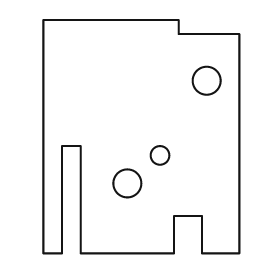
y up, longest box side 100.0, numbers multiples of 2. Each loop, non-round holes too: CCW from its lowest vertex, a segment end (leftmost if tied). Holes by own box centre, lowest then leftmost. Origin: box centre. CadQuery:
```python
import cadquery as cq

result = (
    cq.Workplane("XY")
    .moveTo(-42.0, -50.0)
    .lineTo(-34.0, -50.0)
    .lineTo(-34.0, -4.0)
    .lineTo(-26.0, -4.0)
    .lineTo(-26.0, -50.0)
    .lineTo(14.0, -50.0)
    .lineTo(14.0, -34.0)
    .lineTo(26.0, -34.0)
    .lineTo(26.0, -50.0)
    .lineTo(42.0, -50.0)
    .lineTo(42.0, 44.0)
    .lineTo(16.0, 44.0)
    .lineTo(16.0, 50.0)
    .lineTo(-42.0, 50.0)
    .close()
    .moveTo(-6.0, -20.0)
    .circle(6.0)
    .moveTo(8.0, -8.0)
    .circle(4.0)
    .moveTo(28.0, 24.0)
    .circle(6.0)
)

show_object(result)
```